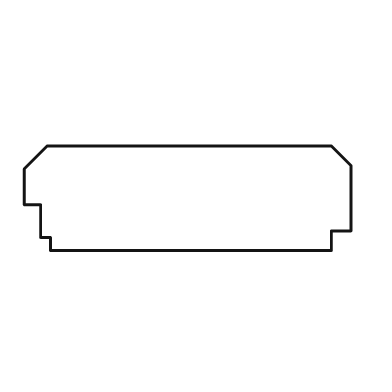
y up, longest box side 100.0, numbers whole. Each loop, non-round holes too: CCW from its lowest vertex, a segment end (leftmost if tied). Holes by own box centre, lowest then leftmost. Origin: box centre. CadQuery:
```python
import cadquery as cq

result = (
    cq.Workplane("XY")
    .moveTo(-42.0, -16.0)
    .lineTo(44.0, -16.0)
    .lineTo(44.0, -10.0)
    .lineTo(50.0, -10.0)
    .lineTo(50.0, 10.0)
    .lineTo(44.0, 16.0)
    .lineTo(-43.0, 16.0)
    .lineTo(-50.0, 9.0)
    .lineTo(-50.0, -2.0)
    .lineTo(-45.0, -2.0)
    .lineTo(-45.0, -12.0)
    .lineTo(-42.0, -12.0)
    .close()
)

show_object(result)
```